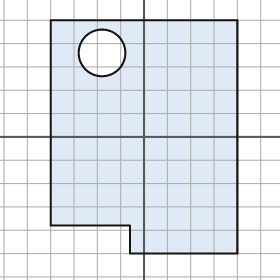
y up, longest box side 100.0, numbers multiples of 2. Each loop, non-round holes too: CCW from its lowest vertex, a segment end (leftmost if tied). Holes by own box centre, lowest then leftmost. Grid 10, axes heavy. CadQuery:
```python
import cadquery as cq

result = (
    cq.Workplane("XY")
    .moveTo(-6.0, -50.0)
    .lineTo(40.0, -50.0)
    .lineTo(40.0, 50.0)
    .lineTo(-40.0, 50.0)
    .lineTo(-40.0, -38.0)
    .lineTo(-6.0, -38.0)
    .close()
    .moveTo(-18.0, 36.0)
    .circle(10.0)
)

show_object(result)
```